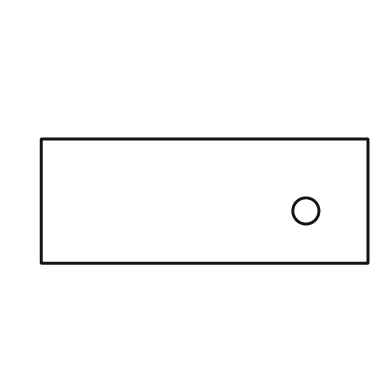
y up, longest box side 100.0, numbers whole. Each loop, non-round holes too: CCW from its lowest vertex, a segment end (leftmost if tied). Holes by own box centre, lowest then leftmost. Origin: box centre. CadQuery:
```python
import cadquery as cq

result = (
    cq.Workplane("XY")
    .moveTo(-50.0, -19.0)
    .lineTo(50.0, -19.0)
    .lineTo(50.0, 19.0)
    .lineTo(-50.0, 19.0)
    .close()
    .moveTo(31.0, -3.0)
    .circle(4.0)
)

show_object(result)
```